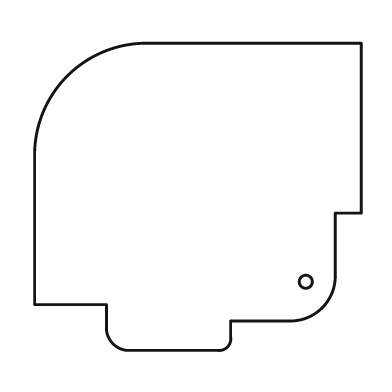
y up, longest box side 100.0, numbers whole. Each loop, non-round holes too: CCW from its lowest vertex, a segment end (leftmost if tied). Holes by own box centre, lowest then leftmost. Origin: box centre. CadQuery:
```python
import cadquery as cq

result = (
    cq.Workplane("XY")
    .moveTo(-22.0, -47.0)
    .lineTo(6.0, -47.0)
    .threePointArc((9.0, -46.0), (10.0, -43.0))
    .lineTo(10.0, -38.0)
    .lineTo(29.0, -38.0)
    .threePointArc((38.0, -34.0), (42.0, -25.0))
    .lineTo(42.0, -5.0)
    .lineTo(50.0, -5.0)
    .lineTo(50.0, 47.0)
    .lineTo(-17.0, 47.0)
    .threePointArc((-40.0, 37.0), (-50.0, 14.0))
    .lineTo(-50.0, -33.0)
    .lineTo(-28.0, -33.0)
    .lineTo(-28.0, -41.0)
    .threePointArc((-26.0, -45.0), (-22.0, -47.0))
    .close()
    .moveTo(33.0, -26.0)
    .circle(2.0)
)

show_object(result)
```